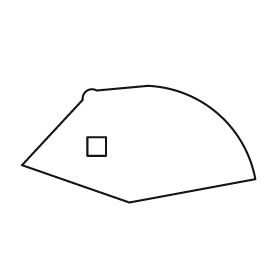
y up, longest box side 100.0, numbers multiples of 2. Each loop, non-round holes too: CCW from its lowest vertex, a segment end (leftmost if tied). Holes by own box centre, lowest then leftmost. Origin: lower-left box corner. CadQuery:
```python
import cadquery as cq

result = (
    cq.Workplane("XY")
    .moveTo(46.0, 0.0)
    .lineTo(100.0, 10.0)
    .threePointArc((84.0, 38.0), (54.0, 50.0))
    .lineTo(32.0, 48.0)
    .threePointArc((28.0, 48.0), (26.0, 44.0))
    .lineTo(0.0, 16.0)
    .close()
    .moveTo(28.0, 20.0)
    .lineTo(36.0, 20.0)
    .lineTo(36.0, 28.0)
    .lineTo(28.0, 28.0)
    .close()
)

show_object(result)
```